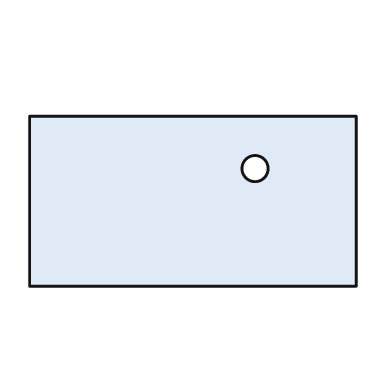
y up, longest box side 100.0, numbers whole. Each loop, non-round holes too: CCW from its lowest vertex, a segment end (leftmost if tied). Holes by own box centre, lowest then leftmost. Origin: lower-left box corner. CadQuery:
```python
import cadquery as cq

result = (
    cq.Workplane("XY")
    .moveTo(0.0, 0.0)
    .lineTo(100.0, 0.0)
    .lineTo(100.0, 52.0)
    .lineTo(0.0, 52.0)
    .close()
    .moveTo(69.0, 36.0)
    .circle(4.0)
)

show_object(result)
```